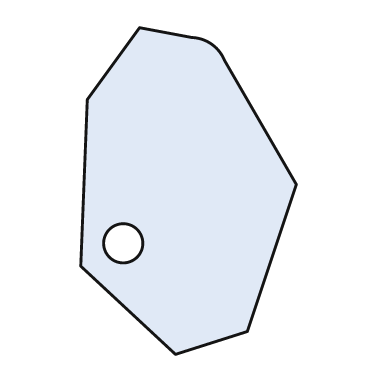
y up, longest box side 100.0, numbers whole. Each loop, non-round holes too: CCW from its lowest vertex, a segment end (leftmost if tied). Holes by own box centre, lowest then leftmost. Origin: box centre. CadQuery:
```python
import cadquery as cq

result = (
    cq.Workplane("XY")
    .moveTo(-4.0, -50.0)
    .lineTo(18.0, -43.0)
    .lineTo(33.0, 2.0)
    .lineTo(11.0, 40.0)
    .threePointArc((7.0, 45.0), (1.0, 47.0))
    .lineTo(-15.0, 50.0)
    .lineTo(-31.0, 28.0)
    .lineTo(-33.0, -23.0)
    .close()
    .moveTo(-20.0, -16.0)
    .circle(6.0)
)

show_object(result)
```